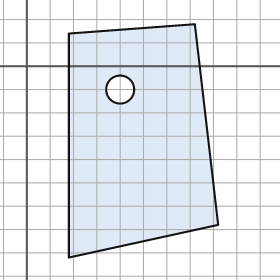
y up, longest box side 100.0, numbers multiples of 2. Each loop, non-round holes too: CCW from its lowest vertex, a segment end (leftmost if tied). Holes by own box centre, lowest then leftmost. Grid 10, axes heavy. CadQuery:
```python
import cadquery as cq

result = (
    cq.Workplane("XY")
    .moveTo(18.0, -82.0)
    .lineTo(82.0, -68.0)
    .lineTo(72.0, 18.0)
    .lineTo(18.0, 14.0)
    .close()
    .moveTo(40.0, -10.0)
    .circle(6.0)
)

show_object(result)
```